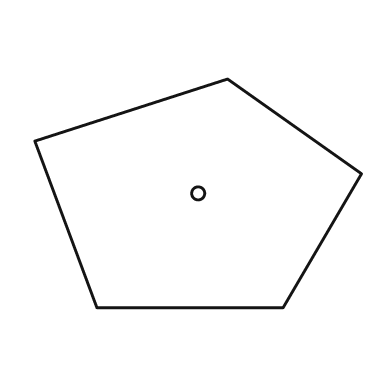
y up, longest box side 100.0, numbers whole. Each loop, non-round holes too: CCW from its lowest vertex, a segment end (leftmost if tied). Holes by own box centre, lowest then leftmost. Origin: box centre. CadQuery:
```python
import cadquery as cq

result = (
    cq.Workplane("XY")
    .moveTo(-31.0, -35.0)
    .lineTo(26.0, -35.0)
    .lineTo(50.0, 6.0)
    .lineTo(9.0, 35.0)
    .lineTo(-50.0, 16.0)
    .close()
    .moveTo(0.0, 0.0)
    .circle(2.0)
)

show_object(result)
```